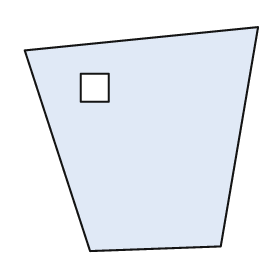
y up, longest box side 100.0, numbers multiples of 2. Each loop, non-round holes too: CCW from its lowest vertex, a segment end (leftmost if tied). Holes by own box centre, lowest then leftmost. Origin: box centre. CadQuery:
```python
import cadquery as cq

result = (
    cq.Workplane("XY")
    .moveTo(-22.0, -48.0)
    .lineTo(34.0, -46.0)
    .lineTo(50.0, 48.0)
    .lineTo(-50.0, 38.0)
    .close()
    .moveTo(-26.0, 16.0)
    .lineTo(-14.0, 16.0)
    .lineTo(-14.0, 28.0)
    .lineTo(-26.0, 28.0)
    .close()
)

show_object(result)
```